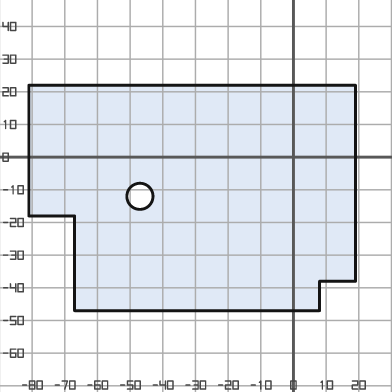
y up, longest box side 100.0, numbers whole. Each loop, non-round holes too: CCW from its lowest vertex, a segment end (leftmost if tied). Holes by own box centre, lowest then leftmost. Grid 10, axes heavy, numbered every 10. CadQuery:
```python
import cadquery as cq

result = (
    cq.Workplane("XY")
    .moveTo(-67.0, -47.0)
    .lineTo(8.0, -47.0)
    .lineTo(8.0, -38.0)
    .lineTo(19.0, -38.0)
    .lineTo(19.0, 22.0)
    .lineTo(-81.0, 22.0)
    .lineTo(-81.0, -18.0)
    .lineTo(-67.0, -18.0)
    .close()
    .moveTo(-47.0, -12.0)
    .circle(4.0)
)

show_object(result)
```